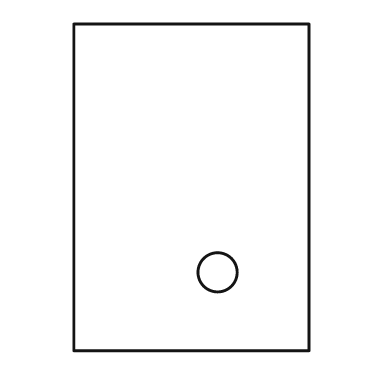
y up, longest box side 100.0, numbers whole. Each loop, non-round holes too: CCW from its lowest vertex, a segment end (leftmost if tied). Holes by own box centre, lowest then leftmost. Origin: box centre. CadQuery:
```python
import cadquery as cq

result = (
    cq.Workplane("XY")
    .moveTo(-36.0, -50.0)
    .lineTo(36.0, -50.0)
    .lineTo(36.0, 50.0)
    .lineTo(-36.0, 50.0)
    .close()
    .moveTo(8.0, -26.0)
    .circle(6.0)
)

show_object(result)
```